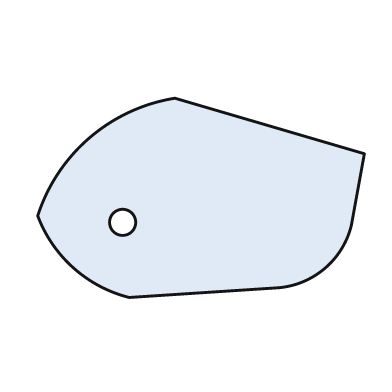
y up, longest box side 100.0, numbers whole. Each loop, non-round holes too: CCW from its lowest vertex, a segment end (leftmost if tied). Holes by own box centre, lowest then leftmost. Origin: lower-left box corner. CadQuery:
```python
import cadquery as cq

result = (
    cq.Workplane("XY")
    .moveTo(28.0, 0.0)
    .lineTo(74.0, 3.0)
    .threePointArc((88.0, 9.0), (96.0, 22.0))
    .lineTo(100.0, 44.0)
    .lineTo(42.0, 61.0)
    .threePointArc((16.0, 49.0), (0.0, 25.0))
    .threePointArc((11.0, 9.0), (28.0, 0.0))
    .close()
    .moveTo(26.0, 23.0)
    .circle(4.0)
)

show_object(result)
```